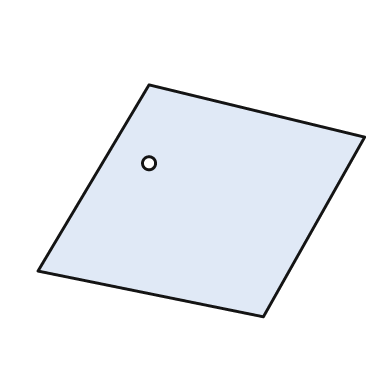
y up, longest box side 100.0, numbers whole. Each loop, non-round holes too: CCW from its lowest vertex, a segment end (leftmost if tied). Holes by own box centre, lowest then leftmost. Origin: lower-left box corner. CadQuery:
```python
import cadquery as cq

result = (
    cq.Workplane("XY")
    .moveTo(69.0, 0.0)
    .lineTo(100.0, 55.0)
    .lineTo(34.0, 71.0)
    .lineTo(0.0, 14.0)
    .close()
    .moveTo(34.0, 47.0)
    .circle(2.0)
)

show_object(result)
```